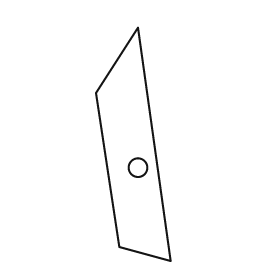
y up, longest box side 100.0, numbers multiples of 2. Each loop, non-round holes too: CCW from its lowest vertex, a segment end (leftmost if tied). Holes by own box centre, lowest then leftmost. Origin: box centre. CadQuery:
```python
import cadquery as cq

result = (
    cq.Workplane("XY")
    .moveTo(16.0, -50.0)
    .lineTo(2.0, 50.0)
    .lineTo(-16.0, 22.0)
    .lineTo(-6.0, -44.0)
    .close()
    .moveTo(2.0, -10.0)
    .circle(4.0)
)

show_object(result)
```